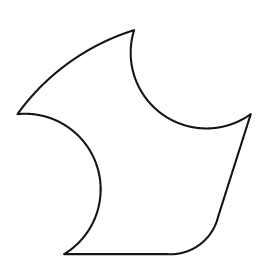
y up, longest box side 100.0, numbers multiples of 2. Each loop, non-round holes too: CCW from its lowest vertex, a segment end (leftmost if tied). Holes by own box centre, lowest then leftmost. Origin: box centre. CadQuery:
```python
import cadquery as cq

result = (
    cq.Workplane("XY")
    .moveTo(-30.0, -48.0)
    .lineTo(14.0, -48.0)
    .threePointArc((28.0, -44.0), (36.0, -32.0))
    .lineTo(50.0, 12.0)
    .threePointArc((12.0, 12.0), (0.0, 48.0))
    .threePointArc((-28.0, 34.0), (-50.0, 12.0))
    .threePointArc((-16.0, -10.0), (-30.0, -48.0))
    .close()
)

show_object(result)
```